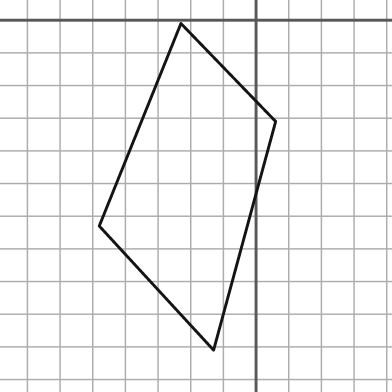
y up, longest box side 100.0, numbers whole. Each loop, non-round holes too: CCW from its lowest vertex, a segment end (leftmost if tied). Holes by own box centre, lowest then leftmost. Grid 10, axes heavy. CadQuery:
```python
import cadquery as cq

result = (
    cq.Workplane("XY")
    .moveTo(-13.0, -101.0)
    .lineTo(6.0, -31.0)
    .lineTo(-23.0, -1.0)
    .lineTo(-48.0, -63.0)
    .close()
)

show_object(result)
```